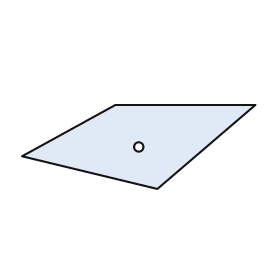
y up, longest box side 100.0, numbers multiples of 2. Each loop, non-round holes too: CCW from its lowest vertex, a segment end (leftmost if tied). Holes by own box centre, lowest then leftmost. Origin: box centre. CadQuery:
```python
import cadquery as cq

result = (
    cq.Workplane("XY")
    .moveTo(8.0, -18.0)
    .lineTo(50.0, 18.0)
    .lineTo(-10.0, 18.0)
    .lineTo(-50.0, -4.0)
    .close()
    .moveTo(0.0, 0.0)
    .circle(2.0)
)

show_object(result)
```